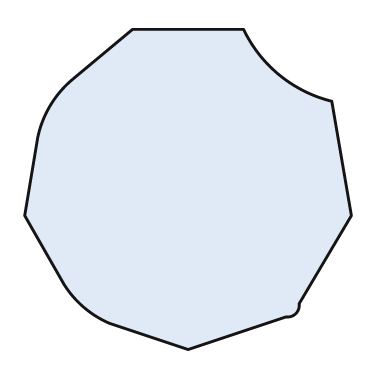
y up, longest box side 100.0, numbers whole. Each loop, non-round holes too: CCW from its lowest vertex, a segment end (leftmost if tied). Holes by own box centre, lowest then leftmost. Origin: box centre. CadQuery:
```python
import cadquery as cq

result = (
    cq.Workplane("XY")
    .moveTo(0.0, -49.0)
    .lineTo(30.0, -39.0)
    .threePointArc((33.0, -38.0), (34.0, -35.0))
    .lineTo(50.0, -8.0)
    .lineTo(44.0, 27.0)
    .threePointArc((28.0, 35.0), (17.0, 49.0))
    .lineTo(-17.0, 49.0)
    .lineTo(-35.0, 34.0)
    .threePointArc((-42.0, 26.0), (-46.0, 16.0))
    .lineTo(-50.0, -8.0)
    .lineTo(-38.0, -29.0)
    .threePointArc((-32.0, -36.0), (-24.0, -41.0))
    .close()
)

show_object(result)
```